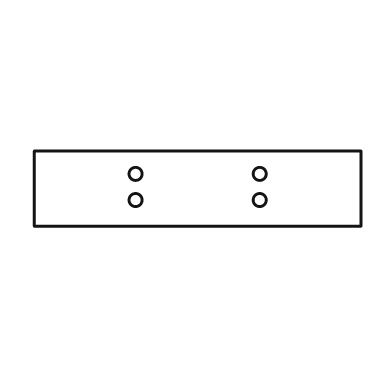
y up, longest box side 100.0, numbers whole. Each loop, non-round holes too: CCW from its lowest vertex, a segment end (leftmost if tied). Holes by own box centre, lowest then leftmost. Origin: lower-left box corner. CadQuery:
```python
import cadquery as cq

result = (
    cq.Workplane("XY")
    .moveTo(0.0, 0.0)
    .lineTo(100.0, 0.0)
    .lineTo(100.0, 23.0)
    .lineTo(0.0, 23.0)
    .close()
    .moveTo(31.0, 8.0)
    .circle(2.0)
    .moveTo(69.0, 8.0)
    .circle(2.0)
    .moveTo(31.0, 16.0)
    .circle(2.0)
    .moveTo(69.0, 16.0)
    .circle(2.0)
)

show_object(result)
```